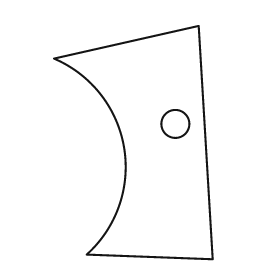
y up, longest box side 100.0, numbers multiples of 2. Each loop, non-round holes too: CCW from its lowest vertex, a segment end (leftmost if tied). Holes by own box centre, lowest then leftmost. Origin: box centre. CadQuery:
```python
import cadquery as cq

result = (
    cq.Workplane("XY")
    .moveTo(34.0, -50.0)
    .lineTo(28.0, 50.0)
    .lineTo(-34.0, 36.0)
    .threePointArc((-4.0, -2.0), (-20.0, -48.0))
    .close()
    .moveTo(18.0, 8.0)
    .circle(6.0)
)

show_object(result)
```